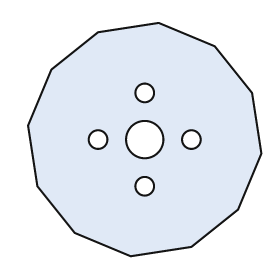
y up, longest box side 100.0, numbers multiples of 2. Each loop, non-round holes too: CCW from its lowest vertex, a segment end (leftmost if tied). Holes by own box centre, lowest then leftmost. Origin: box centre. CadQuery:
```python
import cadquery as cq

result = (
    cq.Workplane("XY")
    .moveTo(-6.0, -50.0)
    .lineTo(20.0, -46.0)
    .lineTo(40.0, -30.0)
    .lineTo(50.0, -6.0)
    .lineTo(46.0, 20.0)
    .lineTo(30.0, 40.0)
    .lineTo(6.0, 50.0)
    .lineTo(-20.0, 46.0)
    .lineTo(-40.0, 30.0)
    .lineTo(-50.0, 6.0)
    .lineTo(-46.0, -20.0)
    .lineTo(-30.0, -40.0)
    .close()
    .moveTo(0.0, -20.0)
    .circle(4.0)
    .moveTo(-20.0, 0.0)
    .circle(4.0)
    .moveTo(0.0, 0.0)
    .circle(8.0)
    .moveTo(20.0, 0.0)
    .circle(4.0)
    .moveTo(0.0, 20.0)
    .circle(4.0)
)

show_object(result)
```